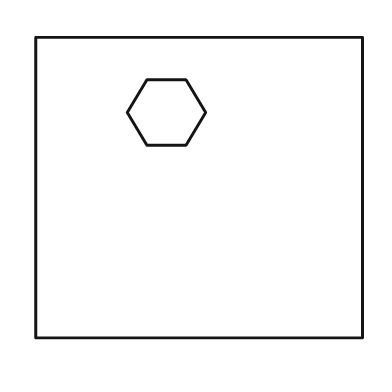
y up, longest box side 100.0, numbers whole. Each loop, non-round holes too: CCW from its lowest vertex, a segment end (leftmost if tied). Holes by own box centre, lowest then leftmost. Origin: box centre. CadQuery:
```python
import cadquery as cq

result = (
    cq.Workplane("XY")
    .moveTo(-50.0, -46.0)
    .lineTo(50.0, -46.0)
    .lineTo(50.0, 46.0)
    .lineTo(-50.0, 46.0)
    .close()
    .moveTo(-16.0, 13.0)
    .lineTo(-4.0, 13.0)
    .lineTo(2.0, 23.0)
    .lineTo(-4.0, 33.0)
    .lineTo(-16.0, 33.0)
    .lineTo(-22.0, 23.0)
    .close()
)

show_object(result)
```